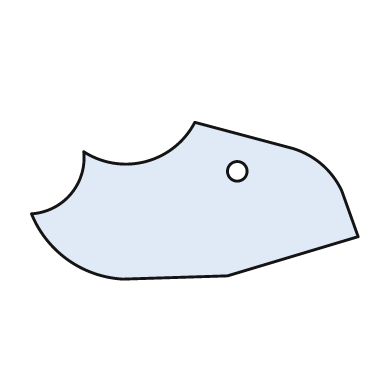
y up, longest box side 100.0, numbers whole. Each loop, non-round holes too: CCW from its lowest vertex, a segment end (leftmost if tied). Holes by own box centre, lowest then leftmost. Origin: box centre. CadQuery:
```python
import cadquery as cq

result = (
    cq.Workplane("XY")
    .moveTo(-22.0, -24.0)
    .lineTo(10.0, -23.0)
    .lineTo(50.0, -11.0)
    .lineTo(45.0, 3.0)
    .threePointArc((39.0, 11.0), (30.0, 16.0))
    .lineTo(0.0, 24.0)
    .threePointArc((-15.0, 12.0), (-34.0, 15.0))
    .threePointArc((-38.0, 2.0), (-50.0, -4.0))
    .threePointArc((-39.0, -18.0), (-22.0, -24.0))
    .close()
    .moveTo(13.0, 9.0)
    .circle(3.0)
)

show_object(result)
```